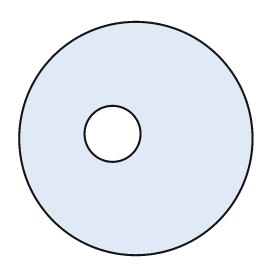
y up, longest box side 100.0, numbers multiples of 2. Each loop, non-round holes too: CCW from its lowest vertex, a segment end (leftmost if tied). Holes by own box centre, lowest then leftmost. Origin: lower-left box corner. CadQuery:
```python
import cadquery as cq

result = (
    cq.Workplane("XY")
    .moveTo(50.0, 50.0)
    .circle(50.0)
    .moveTo(40.0, 52.0)
    .circle(12.0)
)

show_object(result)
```